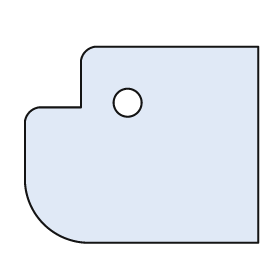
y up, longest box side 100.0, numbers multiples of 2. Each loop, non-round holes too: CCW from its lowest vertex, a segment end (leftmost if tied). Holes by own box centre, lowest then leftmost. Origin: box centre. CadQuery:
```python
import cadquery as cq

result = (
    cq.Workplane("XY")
    .moveTo(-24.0, -42.0)
    .lineTo(50.0, -42.0)
    .lineTo(50.0, 42.0)
    .lineTo(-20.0, 42.0)
    .threePointArc((-24.0, 40.0), (-26.0, 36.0))
    .lineTo(-26.0, 16.0)
    .lineTo(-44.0, 16.0)
    .threePointArc((-48.0, 14.0), (-50.0, 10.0))
    .lineTo(-50.0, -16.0)
    .threePointArc((-42.0, -34.0), (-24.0, -42.0))
    .close()
    .moveTo(-6.0, 18.0)
    .circle(6.0)
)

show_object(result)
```